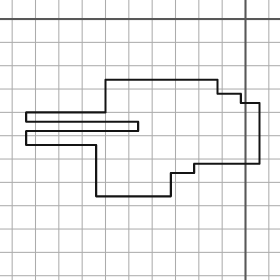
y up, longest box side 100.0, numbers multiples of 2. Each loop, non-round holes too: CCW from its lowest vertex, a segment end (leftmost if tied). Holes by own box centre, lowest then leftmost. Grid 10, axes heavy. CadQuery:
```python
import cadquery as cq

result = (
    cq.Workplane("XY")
    .moveTo(-64.0, -76.0)
    .lineTo(-32.0, -76.0)
    .lineTo(-32.0, -66.0)
    .lineTo(-22.0, -66.0)
    .lineTo(-22.0, -62.0)
    .lineTo(6.0, -62.0)
    .lineTo(6.0, -36.0)
    .lineTo(-2.0, -36.0)
    .lineTo(-2.0, -32.0)
    .lineTo(-12.0, -32.0)
    .lineTo(-12.0, -26.0)
    .lineTo(-60.0, -26.0)
    .lineTo(-60.0, -40.0)
    .lineTo(-94.0, -40.0)
    .lineTo(-94.0, -44.0)
    .lineTo(-46.0, -44.0)
    .lineTo(-46.0, -48.0)
    .lineTo(-94.0, -48.0)
    .lineTo(-94.0, -54.0)
    .lineTo(-64.0, -54.0)
    .close()
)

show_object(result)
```